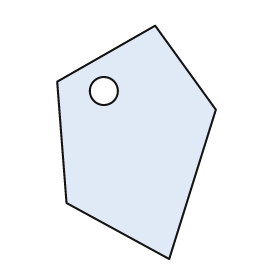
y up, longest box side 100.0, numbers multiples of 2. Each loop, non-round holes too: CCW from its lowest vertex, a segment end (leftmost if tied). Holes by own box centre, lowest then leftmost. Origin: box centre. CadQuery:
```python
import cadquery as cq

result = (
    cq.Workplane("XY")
    .moveTo(14.0, -50.0)
    .lineTo(34.0, 14.0)
    .lineTo(8.0, 50.0)
    .lineTo(-34.0, 26.0)
    .lineTo(-30.0, -26.0)
    .close()
    .moveTo(-14.0, 22.0)
    .circle(6.0)
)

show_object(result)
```